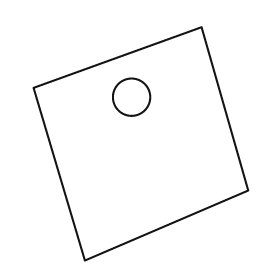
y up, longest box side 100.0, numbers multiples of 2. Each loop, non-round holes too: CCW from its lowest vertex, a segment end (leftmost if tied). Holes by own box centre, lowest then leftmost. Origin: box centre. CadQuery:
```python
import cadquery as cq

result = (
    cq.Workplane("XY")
    .moveTo(-24.0, -50.0)
    .lineTo(46.0, -20.0)
    .lineTo(26.0, 50.0)
    .lineTo(-46.0, 24.0)
    .close()
    .moveTo(-4.0, 20.0)
    .circle(8.0)
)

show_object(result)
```